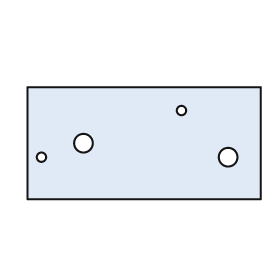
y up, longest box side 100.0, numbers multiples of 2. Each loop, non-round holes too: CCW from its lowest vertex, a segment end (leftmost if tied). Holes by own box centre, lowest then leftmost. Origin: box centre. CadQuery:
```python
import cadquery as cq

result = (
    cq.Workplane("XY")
    .moveTo(-50.0, -24.0)
    .lineTo(50.0, -24.0)
    .lineTo(50.0, 24.0)
    .lineTo(-50.0, 24.0)
    .close()
    .moveTo(-44.0, -6.0)
    .circle(2.0)
    .moveTo(36.0, -6.0)
    .circle(4.0)
    .moveTo(-26.0, 0.0)
    .circle(4.0)
    .moveTo(16.0, 14.0)
    .circle(2.0)
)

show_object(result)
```